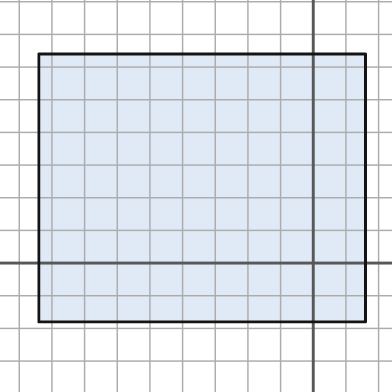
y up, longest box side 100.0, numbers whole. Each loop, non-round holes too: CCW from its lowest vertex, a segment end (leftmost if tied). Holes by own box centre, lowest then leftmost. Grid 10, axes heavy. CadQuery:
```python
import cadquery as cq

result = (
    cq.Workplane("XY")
    .moveTo(-84.0, -18.0)
    .lineTo(16.0, -18.0)
    .lineTo(16.0, 64.0)
    .lineTo(-84.0, 64.0)
    .close()
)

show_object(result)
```